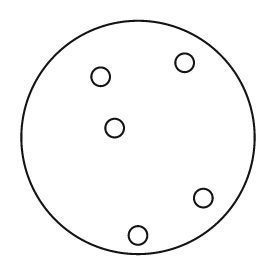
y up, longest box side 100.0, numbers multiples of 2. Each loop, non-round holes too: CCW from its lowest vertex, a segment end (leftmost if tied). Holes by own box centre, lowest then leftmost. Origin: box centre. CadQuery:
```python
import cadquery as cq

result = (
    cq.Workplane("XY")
    .moveTo(0.0, 0.0)
    .circle(50.0)
    .moveTo(0.0, -42.0)
    .circle(4.0)
    .moveTo(28.0, -26.0)
    .circle(4.0)
    .moveTo(-10.0, 4.0)
    .circle(4.0)
    .moveTo(-16.0, 26.0)
    .circle(4.0)
    .moveTo(20.0, 32.0)
    .circle(4.0)
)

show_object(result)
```